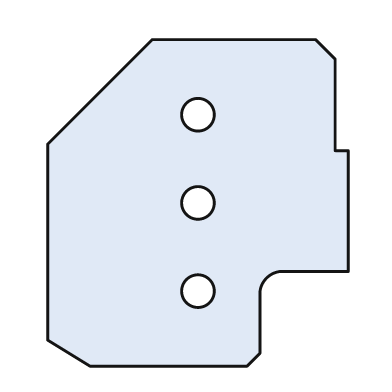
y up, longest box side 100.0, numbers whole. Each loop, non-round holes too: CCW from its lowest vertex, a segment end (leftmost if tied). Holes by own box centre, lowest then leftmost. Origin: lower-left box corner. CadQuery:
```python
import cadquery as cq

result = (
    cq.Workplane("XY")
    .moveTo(13.0, 0.0)
    .lineTo(61.0, 0.0)
    .lineTo(65.0, 4.0)
    .lineTo(65.0, 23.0)
    .threePointArc((67.0, 27.0), (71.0, 29.0))
    .lineTo(92.0, 29.0)
    .lineTo(92.0, 66.0)
    .lineTo(88.0, 66.0)
    .lineTo(88.0, 94.0)
    .lineTo(82.0, 100.0)
    .lineTo(32.0, 100.0)
    .lineTo(0.0, 68.0)
    .lineTo(0.0, 8.0)
    .close()
    .moveTo(46.0, 23.0)
    .circle(5.0)
    .moveTo(46.0, 50.0)
    .circle(5.0)
    .moveTo(46.0, 77.0)
    .circle(5.0)
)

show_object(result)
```